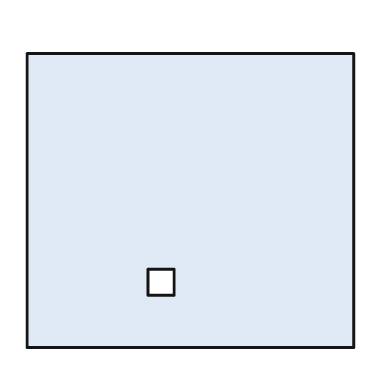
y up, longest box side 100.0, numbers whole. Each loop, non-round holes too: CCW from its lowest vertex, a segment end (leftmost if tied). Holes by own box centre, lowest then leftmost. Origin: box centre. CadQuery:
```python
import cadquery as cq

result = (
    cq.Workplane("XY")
    .moveTo(-50.0, -45.0)
    .lineTo(50.0, -45.0)
    .lineTo(50.0, 45.0)
    .lineTo(-50.0, 45.0)
    .close()
    .moveTo(-13.0, -29.0)
    .lineTo(-5.0, -29.0)
    .lineTo(-5.0, -21.0)
    .lineTo(-13.0, -21.0)
    .close()
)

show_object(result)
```